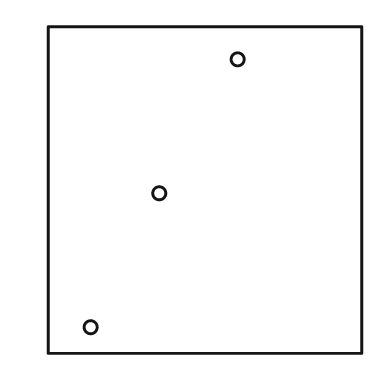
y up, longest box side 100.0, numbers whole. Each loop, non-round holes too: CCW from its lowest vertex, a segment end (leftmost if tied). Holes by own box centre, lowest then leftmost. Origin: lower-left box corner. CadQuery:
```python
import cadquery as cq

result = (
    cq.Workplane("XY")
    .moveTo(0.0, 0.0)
    .lineTo(96.0, 0.0)
    .lineTo(96.0, 100.0)
    .lineTo(0.0, 100.0)
    .close()
    .moveTo(13.0, 8.0)
    .circle(2.0)
    .moveTo(34.0, 49.0)
    .circle(2.0)
    .moveTo(58.0, 90.0)
    .circle(2.0)
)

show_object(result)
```